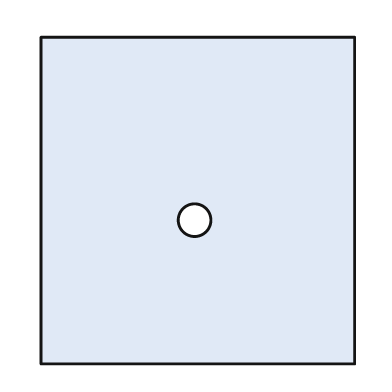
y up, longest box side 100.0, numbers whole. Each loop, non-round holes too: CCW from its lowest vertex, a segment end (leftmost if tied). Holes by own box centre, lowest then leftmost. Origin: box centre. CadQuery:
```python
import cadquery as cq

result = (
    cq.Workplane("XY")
    .moveTo(-48.0, -50.0)
    .lineTo(48.0, -50.0)
    .lineTo(48.0, 50.0)
    .lineTo(-48.0, 50.0)
    .close()
    .moveTo(-1.0, -6.0)
    .circle(5.0)
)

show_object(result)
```